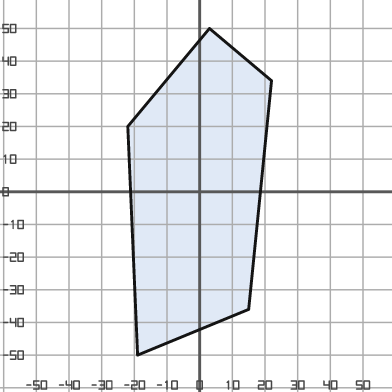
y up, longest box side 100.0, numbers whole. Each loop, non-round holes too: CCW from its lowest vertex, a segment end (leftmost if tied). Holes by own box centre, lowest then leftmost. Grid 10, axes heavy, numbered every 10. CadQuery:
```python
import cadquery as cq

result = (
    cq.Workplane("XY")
    .moveTo(-19.0, -50.0)
    .lineTo(15.0, -36.0)
    .lineTo(22.0, 34.0)
    .lineTo(3.0, 50.0)
    .lineTo(-22.0, 20.0)
    .close()
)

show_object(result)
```